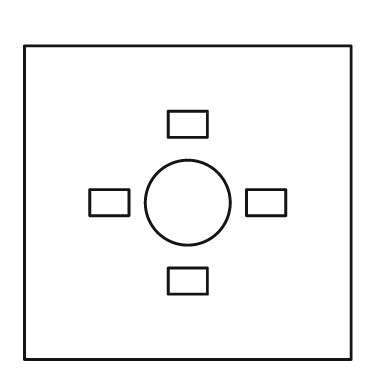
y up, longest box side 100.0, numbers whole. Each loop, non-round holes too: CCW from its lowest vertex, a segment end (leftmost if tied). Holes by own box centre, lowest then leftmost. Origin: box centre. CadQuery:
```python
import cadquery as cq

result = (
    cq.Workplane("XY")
    .moveTo(-50.0, -48.0)
    .lineTo(50.0, -48.0)
    .lineTo(50.0, 48.0)
    .lineTo(-50.0, 48.0)
    .close()
    .moveTo(-6.0, -28.0)
    .lineTo(6.0, -28.0)
    .lineTo(6.0, -20.0)
    .lineTo(-6.0, -20.0)
    .close()
    .moveTo(-30.0, -4.0)
    .lineTo(-18.0, -4.0)
    .lineTo(-18.0, 4.0)
    .lineTo(-30.0, 4.0)
    .close()
    .moveTo(0.0, 0.0)
    .circle(13.0)
    .moveTo(18.0, -4.0)
    .lineTo(30.0, -4.0)
    .lineTo(30.0, 4.0)
    .lineTo(18.0, 4.0)
    .close()
    .moveTo(-6.0, 20.0)
    .lineTo(6.0, 20.0)
    .lineTo(6.0, 28.0)
    .lineTo(-6.0, 28.0)
    .close()
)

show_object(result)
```